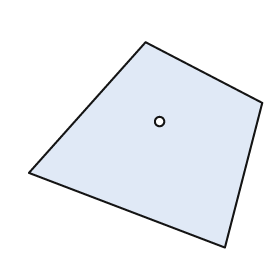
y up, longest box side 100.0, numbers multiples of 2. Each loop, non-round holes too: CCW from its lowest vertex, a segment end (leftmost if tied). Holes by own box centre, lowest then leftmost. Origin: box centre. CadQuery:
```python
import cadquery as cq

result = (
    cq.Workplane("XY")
    .moveTo(34.0, -44.0)
    .lineTo(50.0, 18.0)
    .lineTo(0.0, 44.0)
    .lineTo(-50.0, -12.0)
    .close()
    .moveTo(6.0, 10.0)
    .circle(2.0)
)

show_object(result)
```